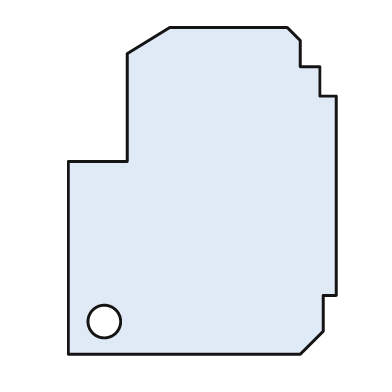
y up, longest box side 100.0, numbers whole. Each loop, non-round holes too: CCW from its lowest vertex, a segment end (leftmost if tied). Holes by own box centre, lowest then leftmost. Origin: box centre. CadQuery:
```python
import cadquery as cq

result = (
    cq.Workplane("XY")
    .moveTo(-41.0, -50.0)
    .lineTo(30.0, -50.0)
    .lineTo(37.0, -43.0)
    .lineTo(37.0, -32.0)
    .lineTo(41.0, -32.0)
    .lineTo(41.0, 29.0)
    .lineTo(36.0, 29.0)
    .lineTo(36.0, 38.0)
    .lineTo(30.0, 38.0)
    .lineTo(30.0, 46.0)
    .lineTo(26.0, 50.0)
    .lineTo(-10.0, 50.0)
    .lineTo(-23.0, 42.0)
    .lineTo(-23.0, 9.0)
    .lineTo(-41.0, 9.0)
    .close()
    .moveTo(-30.0, -40.0)
    .circle(5.0)
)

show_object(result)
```